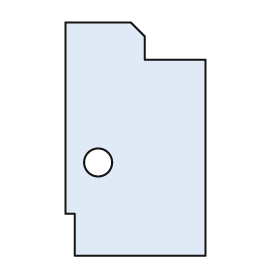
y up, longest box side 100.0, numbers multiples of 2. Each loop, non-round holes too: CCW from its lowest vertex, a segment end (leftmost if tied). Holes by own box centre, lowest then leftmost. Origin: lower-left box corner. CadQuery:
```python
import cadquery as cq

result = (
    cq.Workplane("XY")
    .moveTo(4.0, 0.0)
    .lineTo(60.0, 0.0)
    .lineTo(60.0, 84.0)
    .lineTo(34.0, 84.0)
    .lineTo(34.0, 94.0)
    .lineTo(28.0, 100.0)
    .lineTo(0.0, 100.0)
    .lineTo(0.0, 18.0)
    .lineTo(4.0, 18.0)
    .close()
    .moveTo(14.0, 40.0)
    .circle(6.0)
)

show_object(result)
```